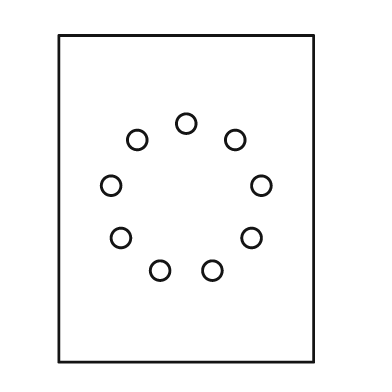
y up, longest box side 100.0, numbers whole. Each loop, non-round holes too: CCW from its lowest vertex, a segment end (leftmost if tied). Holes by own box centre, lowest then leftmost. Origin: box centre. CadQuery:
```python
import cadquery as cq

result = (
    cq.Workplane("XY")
    .moveTo(-39.0, -50.0)
    .lineTo(39.0, -50.0)
    .lineTo(39.0, 50.0)
    .lineTo(-39.0, 50.0)
    .close()
    .moveTo(-8.0, -22.0)
    .circle(3.0)
    .moveTo(8.0, -22.0)
    .circle(3.0)
    .moveTo(-20.0, -12.0)
    .circle(3.0)
    .moveTo(20.0, -12.0)
    .circle(3.0)
    .moveTo(-23.0, 4.0)
    .circle(3.0)
    .moveTo(23.0, 4.0)
    .circle(3.0)
    .moveTo(-15.0, 18.0)
    .circle(3.0)
    .moveTo(15.0, 18.0)
    .circle(3.0)
    .moveTo(0.0, 23.0)
    .circle(3.0)
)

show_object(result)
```